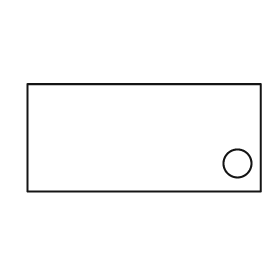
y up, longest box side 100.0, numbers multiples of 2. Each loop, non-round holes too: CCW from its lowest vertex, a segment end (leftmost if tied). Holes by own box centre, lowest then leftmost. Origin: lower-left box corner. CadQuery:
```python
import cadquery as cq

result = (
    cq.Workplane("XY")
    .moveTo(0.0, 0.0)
    .lineTo(100.0, 0.0)
    .lineTo(100.0, 46.0)
    .lineTo(0.0, 46.0)
    .close()
    .moveTo(90.0, 12.0)
    .circle(6.0)
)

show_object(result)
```